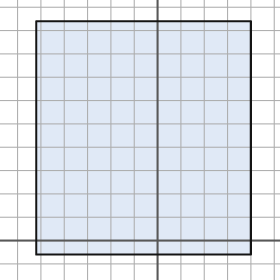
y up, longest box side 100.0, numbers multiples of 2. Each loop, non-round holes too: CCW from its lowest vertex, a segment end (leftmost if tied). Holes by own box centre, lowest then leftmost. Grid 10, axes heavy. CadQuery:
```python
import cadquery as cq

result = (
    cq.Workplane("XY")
    .moveTo(-52.0, -6.0)
    .lineTo(40.0, -6.0)
    .lineTo(40.0, 94.0)
    .lineTo(-52.0, 94.0)
    .close()
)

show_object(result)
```